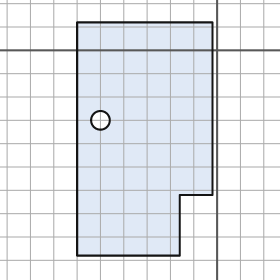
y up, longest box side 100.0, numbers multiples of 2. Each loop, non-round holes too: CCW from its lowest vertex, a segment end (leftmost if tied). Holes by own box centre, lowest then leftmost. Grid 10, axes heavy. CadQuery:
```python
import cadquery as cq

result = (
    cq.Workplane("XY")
    .moveTo(-60.0, -88.0)
    .lineTo(-16.0, -88.0)
    .lineTo(-16.0, -62.0)
    .lineTo(-2.0, -62.0)
    .lineTo(-2.0, 12.0)
    .lineTo(-60.0, 12.0)
    .close()
    .moveTo(-50.0, -30.0)
    .circle(4.0)
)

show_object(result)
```